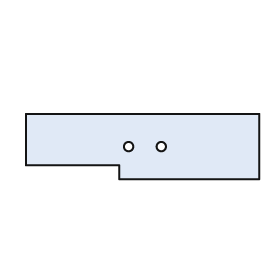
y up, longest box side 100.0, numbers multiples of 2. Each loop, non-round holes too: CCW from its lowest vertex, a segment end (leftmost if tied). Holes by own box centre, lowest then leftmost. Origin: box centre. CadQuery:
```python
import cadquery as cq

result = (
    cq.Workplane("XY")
    .moveTo(-10.0, -14.0)
    .lineTo(50.0, -14.0)
    .lineTo(50.0, 14.0)
    .lineTo(-50.0, 14.0)
    .lineTo(-50.0, -8.0)
    .lineTo(-10.0, -8.0)
    .close()
    .moveTo(-6.0, 0.0)
    .circle(2.0)
    .moveTo(8.0, 0.0)
    .circle(2.0)
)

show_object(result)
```